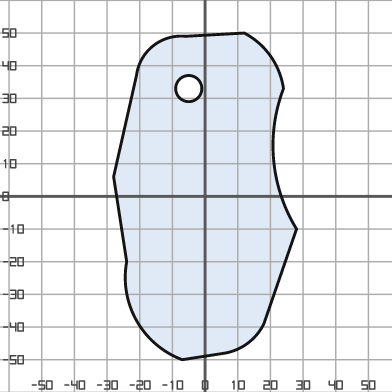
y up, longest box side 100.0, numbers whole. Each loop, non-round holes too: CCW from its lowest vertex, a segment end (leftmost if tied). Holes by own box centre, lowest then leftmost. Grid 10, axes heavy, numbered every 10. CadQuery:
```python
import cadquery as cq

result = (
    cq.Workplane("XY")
    .moveTo(-7.0, -50.0)
    .lineTo(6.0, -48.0)
    .threePointArc((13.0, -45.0), (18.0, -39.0))
    .lineTo(28.0, -10.0)
    .threePointArc((21.0, 11.0), (24.0, 33.0))
    .threePointArc((20.0, 43.0), (12.0, 50.0))
    .lineTo(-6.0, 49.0)
    .threePointArc((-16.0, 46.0), (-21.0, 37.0))
    .lineTo(-28.0, 6.0)
    .lineTo(-24.0, -20.0)
    .threePointArc((-21.0, -38.0), (-7.0, -50.0))
    .close()
    .moveTo(-5.0, 33.0)
    .circle(4.0)
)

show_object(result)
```